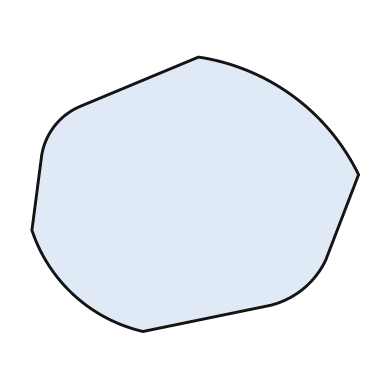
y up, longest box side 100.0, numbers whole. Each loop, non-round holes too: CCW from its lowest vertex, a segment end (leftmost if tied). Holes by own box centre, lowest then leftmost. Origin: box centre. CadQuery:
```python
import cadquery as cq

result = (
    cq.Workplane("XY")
    .moveTo(-16.0, -42.0)
    .lineTo(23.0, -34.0)
    .threePointArc((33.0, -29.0), (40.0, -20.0))
    .lineTo(50.0, 6.0)
    .threePointArc((30.0, 30.0), (1.0, 42.0))
    .lineTo(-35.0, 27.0)
    .threePointArc((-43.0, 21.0), (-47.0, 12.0))
    .lineTo(-50.0, -11.0)
    .threePointArc((-37.0, -31.0), (-16.0, -42.0))
    .close()
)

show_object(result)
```